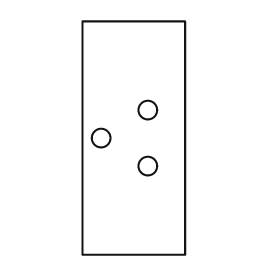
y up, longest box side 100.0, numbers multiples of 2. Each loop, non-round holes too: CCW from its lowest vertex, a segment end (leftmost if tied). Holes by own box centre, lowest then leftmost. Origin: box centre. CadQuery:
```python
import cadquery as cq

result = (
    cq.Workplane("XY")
    .moveTo(-22.0, -50.0)
    .lineTo(22.0, -50.0)
    .lineTo(22.0, 50.0)
    .lineTo(-22.0, 50.0)
    .close()
    .moveTo(6.0, -12.0)
    .circle(4.0)
    .moveTo(-14.0, 0.0)
    .circle(4.0)
    .moveTo(6.0, 12.0)
    .circle(4.0)
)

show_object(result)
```